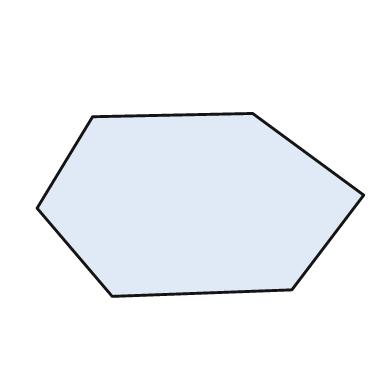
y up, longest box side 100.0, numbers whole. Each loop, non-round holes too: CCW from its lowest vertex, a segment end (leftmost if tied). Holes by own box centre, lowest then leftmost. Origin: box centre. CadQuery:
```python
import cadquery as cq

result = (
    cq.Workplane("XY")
    .moveTo(-27.0, -28.0)
    .lineTo(28.0, -26.0)
    .lineTo(50.0, 3.0)
    .lineTo(16.0, 28.0)
    .lineTo(-33.0, 27.0)
    .lineTo(-50.0, -1.0)
    .close()
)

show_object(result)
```